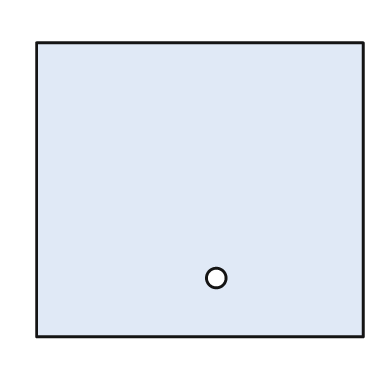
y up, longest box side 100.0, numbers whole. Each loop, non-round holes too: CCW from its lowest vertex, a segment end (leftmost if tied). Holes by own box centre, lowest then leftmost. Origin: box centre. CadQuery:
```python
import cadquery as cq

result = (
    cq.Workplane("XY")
    .moveTo(-50.0, -45.0)
    .lineTo(50.0, -45.0)
    .lineTo(50.0, 45.0)
    .lineTo(-50.0, 45.0)
    .close()
    .moveTo(5.0, -27.0)
    .circle(3.0)
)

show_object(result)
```